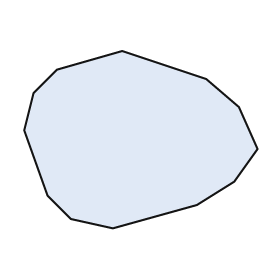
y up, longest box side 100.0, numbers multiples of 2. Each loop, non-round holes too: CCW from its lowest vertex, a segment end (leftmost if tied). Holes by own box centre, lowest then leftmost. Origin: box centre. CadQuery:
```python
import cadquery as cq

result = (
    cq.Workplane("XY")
    .moveTo(-12.0, -38.0)
    .lineTo(24.0, -28.0)
    .lineTo(40.0, -18.0)
    .lineTo(50.0, -4.0)
    .lineTo(42.0, 14.0)
    .lineTo(28.0, 26.0)
    .lineTo(-8.0, 38.0)
    .lineTo(-36.0, 30.0)
    .lineTo(-46.0, 20.0)
    .lineTo(-50.0, 4.0)
    .lineTo(-40.0, -24.0)
    .lineTo(-30.0, -34.0)
    .close()
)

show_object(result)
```